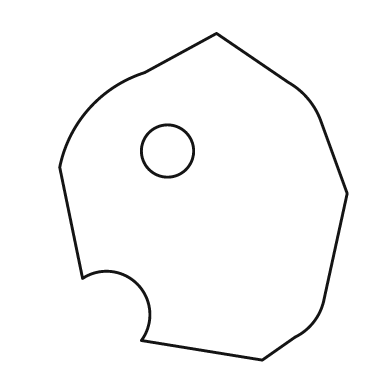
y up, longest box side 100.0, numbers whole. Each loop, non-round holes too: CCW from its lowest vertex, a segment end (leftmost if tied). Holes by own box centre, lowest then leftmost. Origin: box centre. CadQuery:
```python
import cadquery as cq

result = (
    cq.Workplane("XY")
    .moveTo(18.0, -50.0)
    .lineTo(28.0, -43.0)
    .threePointArc((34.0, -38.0), (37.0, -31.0))
    .lineTo(44.0, 1.0)
    .lineTo(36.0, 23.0)
    .threePointArc((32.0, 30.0), (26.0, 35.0))
    .lineTo(4.0, 50.0)
    .lineTo(-18.0, 38.0)
    .threePointArc((-35.0, 27.0), (-44.0, 9.0))
    .lineTo(-37.0, -25.0)
    .threePointArc((-20.0, -27.0), (-19.0, -44.0))
    .close()
    .moveTo(-11.0, 14.0)
    .circle(8.0)
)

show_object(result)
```